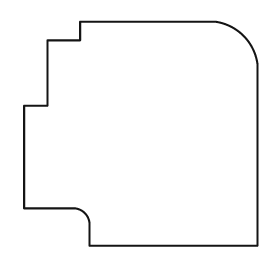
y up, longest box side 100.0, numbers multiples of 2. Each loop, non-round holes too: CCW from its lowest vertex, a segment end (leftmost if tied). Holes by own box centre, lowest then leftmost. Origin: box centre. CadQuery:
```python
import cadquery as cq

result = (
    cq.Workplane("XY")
    .moveTo(-22.0, -48.0)
    .lineTo(50.0, -48.0)
    .lineTo(50.0, 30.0)
    .threePointArc((44.0, 42.0), (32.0, 48.0))
    .lineTo(-26.0, 48.0)
    .lineTo(-26.0, 40.0)
    .lineTo(-40.0, 40.0)
    .lineTo(-40.0, 12.0)
    .lineTo(-50.0, 12.0)
    .lineTo(-50.0, -32.0)
    .lineTo(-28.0, -32.0)
    .threePointArc((-24.0, -34.0), (-22.0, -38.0))
    .close()
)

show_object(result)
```